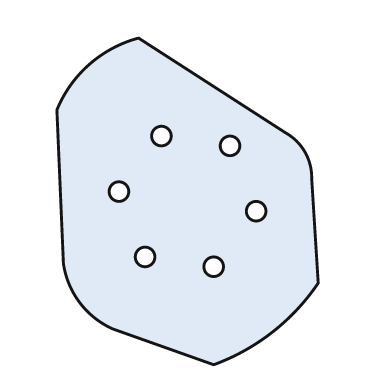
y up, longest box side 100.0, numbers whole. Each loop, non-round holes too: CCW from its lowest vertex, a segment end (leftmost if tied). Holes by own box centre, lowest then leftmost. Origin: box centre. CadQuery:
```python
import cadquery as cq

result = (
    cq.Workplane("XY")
    .moveTo(8.0, -50.0)
    .threePointArc((26.0, -40.0), (40.0, -25.0))
    .lineTo(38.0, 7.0)
    .threePointArc((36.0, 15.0), (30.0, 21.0))
    .lineTo(-15.0, 50.0)
    .threePointArc((-30.0, 42.0), (-40.0, 28.0))
    .lineTo(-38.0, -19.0)
    .threePointArc((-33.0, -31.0), (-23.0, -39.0))
    .close()
    .moveTo(8.0, -20.0)
    .circle(3.0)
    .moveTo(-13.0, -17.0)
    .circle(3.0)
    .moveTo(21.0, -3.0)
    .circle(3.0)
    .moveTo(-21.0, 3.0)
    .circle(3.0)
    .moveTo(13.0, 17.0)
    .circle(3.0)
    .moveTo(-8.0, 20.0)
    .circle(3.0)
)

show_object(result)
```